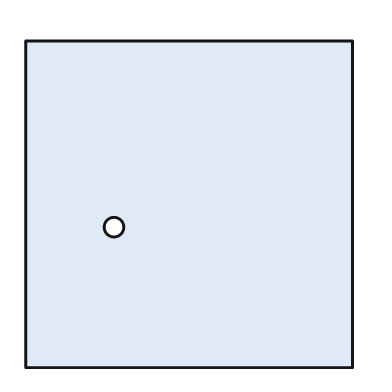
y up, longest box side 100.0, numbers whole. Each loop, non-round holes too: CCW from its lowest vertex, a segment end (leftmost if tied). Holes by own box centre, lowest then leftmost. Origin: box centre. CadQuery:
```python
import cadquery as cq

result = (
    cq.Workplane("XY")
    .moveTo(-50.0, -50.0)
    .lineTo(50.0, -50.0)
    .lineTo(50.0, 50.0)
    .lineTo(-50.0, 50.0)
    .close()
    .moveTo(-23.0, -7.0)
    .circle(3.0)
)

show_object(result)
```